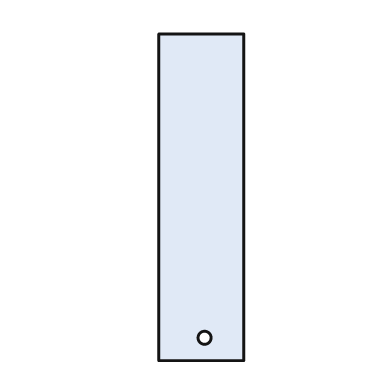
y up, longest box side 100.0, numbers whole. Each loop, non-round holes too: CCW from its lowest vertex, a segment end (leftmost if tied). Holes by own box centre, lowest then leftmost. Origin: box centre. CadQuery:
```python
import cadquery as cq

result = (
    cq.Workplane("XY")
    .moveTo(-13.0, -50.0)
    .lineTo(13.0, -50.0)
    .lineTo(13.0, 50.0)
    .lineTo(-13.0, 50.0)
    .close()
    .moveTo(1.0, -43.0)
    .circle(2.0)
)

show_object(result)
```